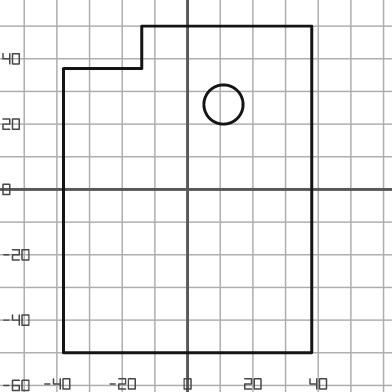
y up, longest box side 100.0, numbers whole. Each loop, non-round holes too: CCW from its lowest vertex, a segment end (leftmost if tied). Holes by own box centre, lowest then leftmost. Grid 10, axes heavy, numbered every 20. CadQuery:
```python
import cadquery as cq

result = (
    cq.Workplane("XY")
    .moveTo(-38.0, -50.0)
    .lineTo(38.0, -50.0)
    .lineTo(38.0, 50.0)
    .lineTo(-14.0, 50.0)
    .lineTo(-14.0, 37.0)
    .lineTo(-38.0, 37.0)
    .close()
    .moveTo(11.0, 26.0)
    .circle(6.0)
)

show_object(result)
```